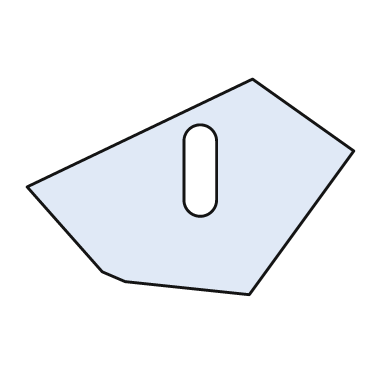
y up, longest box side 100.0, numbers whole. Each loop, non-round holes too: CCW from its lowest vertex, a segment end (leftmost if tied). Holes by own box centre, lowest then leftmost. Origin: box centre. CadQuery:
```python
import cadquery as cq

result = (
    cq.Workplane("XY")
    .moveTo(18.0, -33.0)
    .lineTo(50.0, 11.0)
    .lineTo(19.0, 33.0)
    .lineTo(-50.0, 0.0)
    .lineTo(-27.0, -26.0)
    .lineTo(-20.0, -29.0)
    .close()
    .moveTo(-2.0, -4.0)
    .threePointArc((3.0, -9.0), (8.0, -4.0))
    .lineTo(8.0, 14.0)
    .threePointArc((3.0, 19.0), (-2.0, 14.0))
    .close()
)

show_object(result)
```